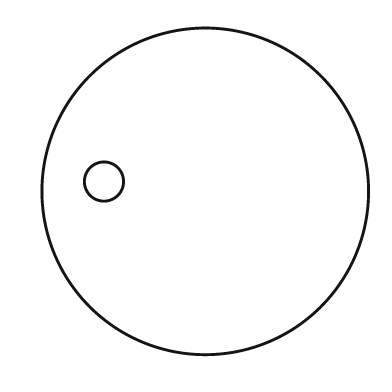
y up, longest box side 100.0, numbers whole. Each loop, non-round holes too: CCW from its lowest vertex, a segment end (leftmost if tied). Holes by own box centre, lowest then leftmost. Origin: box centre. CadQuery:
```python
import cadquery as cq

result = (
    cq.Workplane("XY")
    .moveTo(0.0, 0.0)
    .circle(50.0)
    .moveTo(-31.0, 3.0)
    .circle(6.0)
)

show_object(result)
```